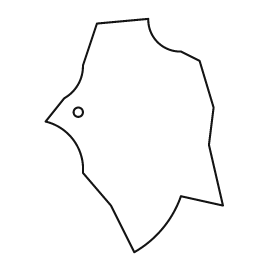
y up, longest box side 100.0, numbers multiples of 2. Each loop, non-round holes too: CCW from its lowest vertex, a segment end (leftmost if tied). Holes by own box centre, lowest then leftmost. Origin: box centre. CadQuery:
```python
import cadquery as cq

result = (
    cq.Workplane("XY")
    .moveTo(0.0, -50.0)
    .threePointArc((12.0, -40.0), (20.0, -26.0))
    .lineTo(38.0, -30.0)
    .lineTo(32.0, -4.0)
    .lineTo(34.0, 12.0)
    .lineTo(28.0, 32.0)
    .lineTo(20.0, 36.0)
    .threePointArc((10.0, 40.0), (6.0, 50.0))
    .lineTo(-16.0, 48.0)
    .lineTo(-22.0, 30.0)
    .threePointArc((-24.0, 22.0), (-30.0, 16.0))
    .lineTo(-38.0, 6.0)
    .threePointArc((-26.0, -2.0), (-22.0, -16.0))
    .lineTo(-10.0, -30.0)
    .close()
    .moveTo(-24.0, 10.0)
    .circle(2.0)
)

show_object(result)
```